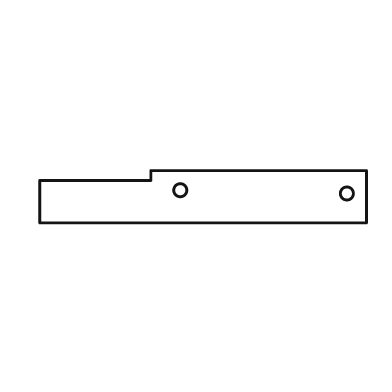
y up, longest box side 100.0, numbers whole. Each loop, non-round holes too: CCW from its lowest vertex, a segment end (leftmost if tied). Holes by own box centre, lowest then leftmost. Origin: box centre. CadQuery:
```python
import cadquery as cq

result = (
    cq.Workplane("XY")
    .moveTo(-50.0, -8.0)
    .lineTo(50.0, -8.0)
    .lineTo(50.0, 8.0)
    .lineTo(-16.0, 8.0)
    .lineTo(-16.0, 5.0)
    .lineTo(-50.0, 5.0)
    .close()
    .moveTo(44.0, 1.0)
    .circle(2.0)
    .moveTo(-7.0, 2.0)
    .circle(2.0)
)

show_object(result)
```